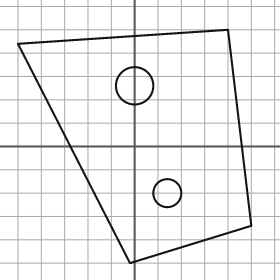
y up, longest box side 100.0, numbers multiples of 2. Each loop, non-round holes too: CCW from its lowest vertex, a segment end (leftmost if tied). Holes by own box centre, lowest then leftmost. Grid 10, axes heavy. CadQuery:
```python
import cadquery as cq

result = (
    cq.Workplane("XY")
    .moveTo(-2.0, -50.0)
    .lineTo(50.0, -34.0)
    .lineTo(40.0, 50.0)
    .lineTo(-50.0, 44.0)
    .close()
    .moveTo(14.0, -20.0)
    .circle(6.0)
    .moveTo(0.0, 26.0)
    .circle(8.0)
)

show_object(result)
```